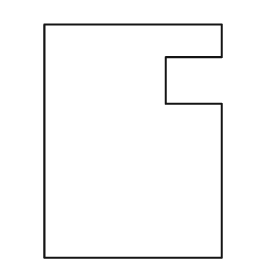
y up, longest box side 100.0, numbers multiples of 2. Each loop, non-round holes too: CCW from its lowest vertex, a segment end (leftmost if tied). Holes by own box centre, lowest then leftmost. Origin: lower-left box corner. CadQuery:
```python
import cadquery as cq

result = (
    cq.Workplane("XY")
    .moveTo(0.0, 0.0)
    .lineTo(76.0, 0.0)
    .lineTo(76.0, 66.0)
    .lineTo(52.0, 66.0)
    .lineTo(52.0, 86.0)
    .lineTo(76.0, 86.0)
    .lineTo(76.0, 100.0)
    .lineTo(0.0, 100.0)
    .close()
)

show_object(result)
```